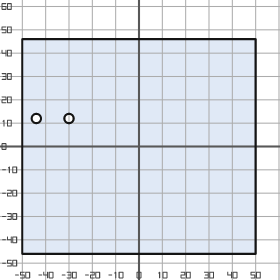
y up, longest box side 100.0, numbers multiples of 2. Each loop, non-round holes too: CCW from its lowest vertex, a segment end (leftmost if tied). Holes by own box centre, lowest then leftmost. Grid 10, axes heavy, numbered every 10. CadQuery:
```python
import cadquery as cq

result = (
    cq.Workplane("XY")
    .moveTo(-50.0, -46.0)
    .lineTo(50.0, -46.0)
    .lineTo(50.0, 46.0)
    .lineTo(-50.0, 46.0)
    .close()
    .moveTo(-44.0, 12.0)
    .circle(2.0)
    .moveTo(-30.0, 12.0)
    .circle(2.0)
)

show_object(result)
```